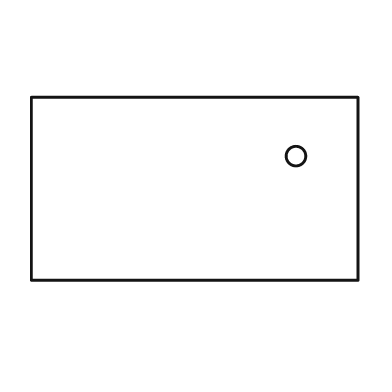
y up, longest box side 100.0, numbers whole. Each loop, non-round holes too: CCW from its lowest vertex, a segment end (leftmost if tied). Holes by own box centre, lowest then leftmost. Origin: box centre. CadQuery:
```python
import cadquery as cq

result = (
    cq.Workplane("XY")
    .moveTo(-50.0, -28.0)
    .lineTo(50.0, -28.0)
    .lineTo(50.0, 28.0)
    .lineTo(-50.0, 28.0)
    .close()
    .moveTo(31.0, 10.0)
    .circle(3.0)
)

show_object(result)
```